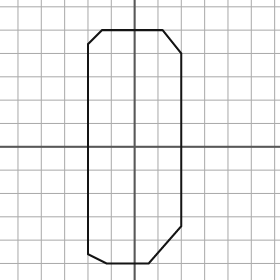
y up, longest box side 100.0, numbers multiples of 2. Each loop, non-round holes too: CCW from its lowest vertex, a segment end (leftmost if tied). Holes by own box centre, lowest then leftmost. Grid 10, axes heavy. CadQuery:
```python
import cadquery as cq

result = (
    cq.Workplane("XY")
    .moveTo(-12.0, -50.0)
    .lineTo(6.0, -50.0)
    .lineTo(20.0, -34.0)
    .lineTo(20.0, 40.0)
    .lineTo(12.0, 50.0)
    .lineTo(-14.0, 50.0)
    .lineTo(-20.0, 44.0)
    .lineTo(-20.0, -46.0)
    .close()
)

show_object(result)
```